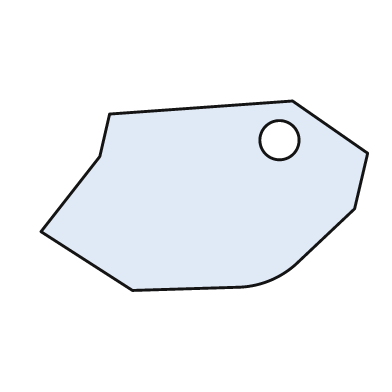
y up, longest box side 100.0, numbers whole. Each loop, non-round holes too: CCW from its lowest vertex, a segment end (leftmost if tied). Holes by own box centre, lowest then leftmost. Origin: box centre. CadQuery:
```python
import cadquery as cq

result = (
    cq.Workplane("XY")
    .moveTo(-22.0, -29.0)
    .lineTo(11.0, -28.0)
    .threePointArc((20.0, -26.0), (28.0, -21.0))
    .lineTo(46.0, -4.0)
    .lineTo(50.0, 13.0)
    .lineTo(27.0, 29.0)
    .lineTo(-29.0, 25.0)
    .lineTo(-32.0, 12.0)
    .lineTo(-50.0, -11.0)
    .close()
    .moveTo(23.0, 17.0)
    .circle(6.0)
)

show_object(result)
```